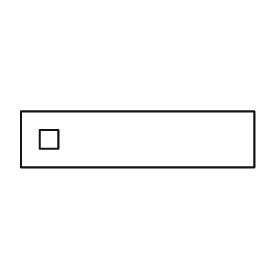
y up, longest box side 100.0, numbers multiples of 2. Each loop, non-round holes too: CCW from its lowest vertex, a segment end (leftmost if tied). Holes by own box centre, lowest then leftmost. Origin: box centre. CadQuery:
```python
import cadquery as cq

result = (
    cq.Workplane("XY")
    .moveTo(-50.0, -12.0)
    .lineTo(50.0, -12.0)
    .lineTo(50.0, 12.0)
    .lineTo(-50.0, 12.0)
    .close()
    .moveTo(-42.0, -4.0)
    .lineTo(-34.0, -4.0)
    .lineTo(-34.0, 4.0)
    .lineTo(-42.0, 4.0)
    .close()
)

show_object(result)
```